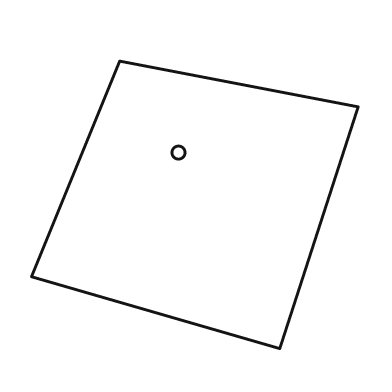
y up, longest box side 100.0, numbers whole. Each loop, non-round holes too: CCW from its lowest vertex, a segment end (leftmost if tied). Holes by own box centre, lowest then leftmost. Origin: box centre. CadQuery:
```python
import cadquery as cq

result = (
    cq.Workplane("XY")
    .moveTo(26.0, -44.0)
    .lineTo(50.0, 30.0)
    .lineTo(-23.0, 44.0)
    .lineTo(-50.0, -22.0)
    .close()
    .moveTo(-5.0, 16.0)
    .circle(2.0)
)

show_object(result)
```